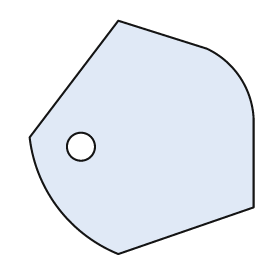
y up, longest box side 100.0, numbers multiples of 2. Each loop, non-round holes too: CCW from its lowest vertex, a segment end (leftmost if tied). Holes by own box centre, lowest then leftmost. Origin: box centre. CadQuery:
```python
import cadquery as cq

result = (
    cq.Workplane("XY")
    .moveTo(-10.0, -50.0)
    .lineTo(48.0, -30.0)
    .lineTo(48.0, 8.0)
    .threePointArc((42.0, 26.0), (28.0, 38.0))
    .lineTo(-10.0, 50.0)
    .lineTo(-48.0, 0.0)
    .threePointArc((-36.0, -30.0), (-10.0, -50.0))
    .close()
    .moveTo(-26.0, -4.0)
    .circle(6.0)
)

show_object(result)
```